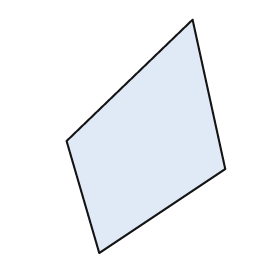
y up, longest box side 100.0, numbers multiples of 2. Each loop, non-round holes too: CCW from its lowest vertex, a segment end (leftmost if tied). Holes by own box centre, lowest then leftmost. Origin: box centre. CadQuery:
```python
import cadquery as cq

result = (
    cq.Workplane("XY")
    .moveTo(-20.0, -50.0)
    .lineTo(34.0, -14.0)
    .lineTo(20.0, 50.0)
    .lineTo(-34.0, -2.0)
    .close()
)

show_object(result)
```